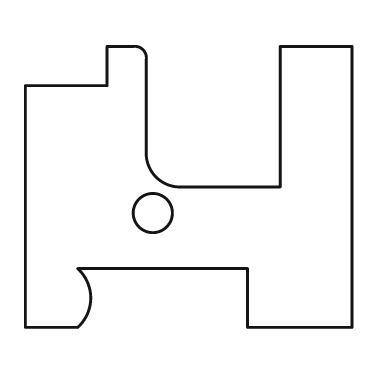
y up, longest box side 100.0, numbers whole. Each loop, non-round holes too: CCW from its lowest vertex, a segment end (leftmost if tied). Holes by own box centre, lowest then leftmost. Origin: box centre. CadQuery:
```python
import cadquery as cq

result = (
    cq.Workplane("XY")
    .moveTo(-50.0, -43.0)
    .lineTo(-34.0, -43.0)
    .threePointArc((-30.0, -34.0), (-34.0, -25.0))
    .lineTo(18.0, -25.0)
    .lineTo(18.0, -43.0)
    .lineTo(50.0, -43.0)
    .lineTo(50.0, 43.0)
    .lineTo(28.0, 43.0)
    .lineTo(28.0, 0.0)
    .lineTo(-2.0, 0.0)
    .threePointArc((-10.0, 3.0), (-13.0, 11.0))
    .lineTo(-13.0, 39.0)
    .threePointArc((-14.0, 42.0), (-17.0, 43.0))
    .lineTo(-25.0, 43.0)
    .lineTo(-25.0, 31.0)
    .lineTo(-50.0, 31.0)
    .close()
    .moveTo(-11.0, -8.0)
    .circle(6.0)
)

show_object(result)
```